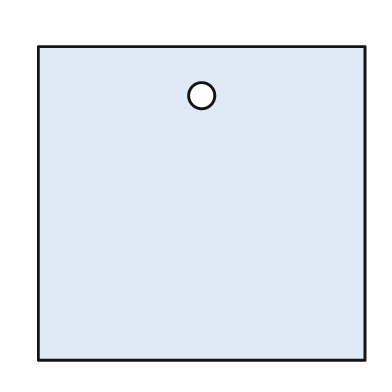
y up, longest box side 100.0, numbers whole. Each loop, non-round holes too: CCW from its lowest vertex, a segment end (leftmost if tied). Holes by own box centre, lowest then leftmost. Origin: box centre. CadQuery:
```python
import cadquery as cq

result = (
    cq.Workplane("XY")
    .moveTo(-50.0, -48.0)
    .lineTo(50.0, -48.0)
    .lineTo(50.0, 48.0)
    .lineTo(-50.0, 48.0)
    .close()
    .moveTo(0.0, 33.0)
    .circle(4.0)
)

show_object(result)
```